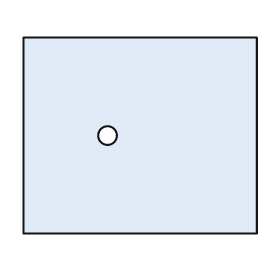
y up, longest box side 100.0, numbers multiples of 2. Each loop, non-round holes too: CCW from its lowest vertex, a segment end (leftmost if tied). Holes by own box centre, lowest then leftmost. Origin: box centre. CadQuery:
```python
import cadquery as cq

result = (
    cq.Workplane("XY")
    .moveTo(-50.0, -42.0)
    .lineTo(50.0, -42.0)
    .lineTo(50.0, 42.0)
    .lineTo(-50.0, 42.0)
    .close()
    .moveTo(-14.0, 0.0)
    .circle(4.0)
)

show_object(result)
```